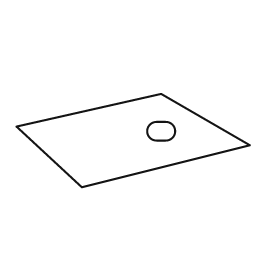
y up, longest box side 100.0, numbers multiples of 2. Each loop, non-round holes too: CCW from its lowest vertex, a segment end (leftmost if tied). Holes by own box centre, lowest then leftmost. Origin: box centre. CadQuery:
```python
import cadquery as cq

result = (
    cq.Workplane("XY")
    .moveTo(-22.0, -20.0)
    .lineTo(50.0, -2.0)
    .lineTo(12.0, 20.0)
    .lineTo(-50.0, 6.0)
    .close()
    .moveTo(10.0, 0.0)
    .lineTo(14.0, 0.0)
    .threePointArc((18.0, 4.0), (14.0, 8.0))
    .lineTo(10.0, 8.0)
    .threePointArc((6.0, 4.0), (10.0, 0.0))
    .close()
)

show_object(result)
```